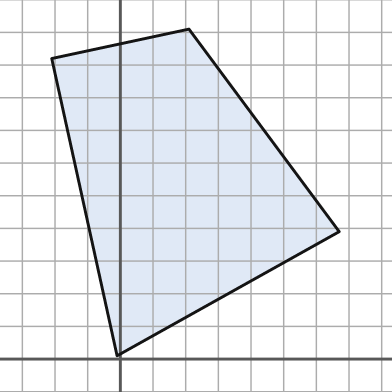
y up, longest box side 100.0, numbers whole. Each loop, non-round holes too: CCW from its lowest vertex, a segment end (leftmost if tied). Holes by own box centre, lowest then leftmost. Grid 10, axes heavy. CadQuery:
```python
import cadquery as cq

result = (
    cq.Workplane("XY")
    .moveTo(-1.0, 1.0)
    .lineTo(67.0, 39.0)
    .lineTo(21.0, 101.0)
    .lineTo(-21.0, 92.0)
    .close()
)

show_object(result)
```